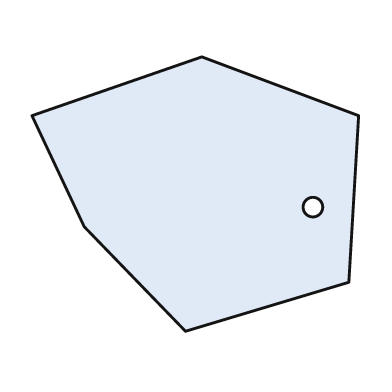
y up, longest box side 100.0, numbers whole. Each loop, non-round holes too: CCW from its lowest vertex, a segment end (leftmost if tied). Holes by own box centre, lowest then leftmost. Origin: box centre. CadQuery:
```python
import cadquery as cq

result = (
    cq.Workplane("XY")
    .moveTo(-3.0, -42.0)
    .lineTo(47.0, -27.0)
    .lineTo(50.0, 24.0)
    .lineTo(2.0, 42.0)
    .lineTo(-50.0, 24.0)
    .lineTo(-34.0, -10.0)
    .close()
    .moveTo(36.0, -4.0)
    .circle(3.0)
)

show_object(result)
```